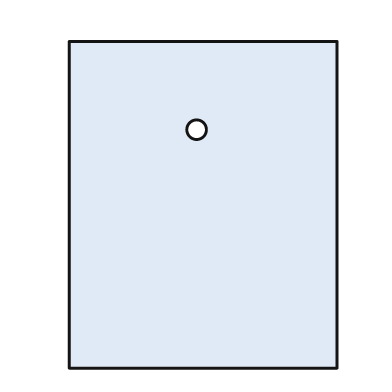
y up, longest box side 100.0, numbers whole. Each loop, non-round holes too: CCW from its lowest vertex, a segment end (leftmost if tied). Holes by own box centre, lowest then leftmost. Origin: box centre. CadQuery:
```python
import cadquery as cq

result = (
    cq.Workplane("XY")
    .moveTo(-41.0, -50.0)
    .lineTo(41.0, -50.0)
    .lineTo(41.0, 50.0)
    .lineTo(-41.0, 50.0)
    .close()
    .moveTo(-2.0, 23.0)
    .circle(3.0)
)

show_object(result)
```